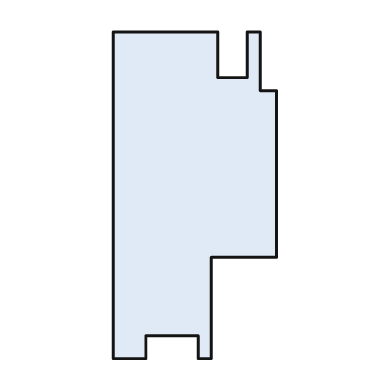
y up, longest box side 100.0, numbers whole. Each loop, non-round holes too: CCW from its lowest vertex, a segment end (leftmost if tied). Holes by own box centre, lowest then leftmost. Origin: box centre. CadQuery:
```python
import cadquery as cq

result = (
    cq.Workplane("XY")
    .moveTo(-25.0, -50.0)
    .lineTo(-15.0, -50.0)
    .lineTo(-15.0, -43.0)
    .lineTo(1.0, -43.0)
    .lineTo(1.0, -50.0)
    .lineTo(5.0, -50.0)
    .lineTo(5.0, -19.0)
    .lineTo(25.0, -19.0)
    .lineTo(25.0, 32.0)
    .lineTo(20.0, 32.0)
    .lineTo(20.0, 50.0)
    .lineTo(16.0, 50.0)
    .lineTo(16.0, 36.0)
    .lineTo(7.0, 36.0)
    .lineTo(7.0, 50.0)
    .lineTo(-25.0, 50.0)
    .close()
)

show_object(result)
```